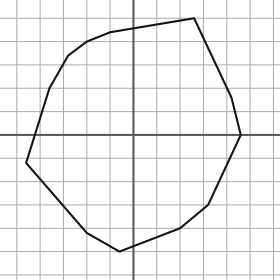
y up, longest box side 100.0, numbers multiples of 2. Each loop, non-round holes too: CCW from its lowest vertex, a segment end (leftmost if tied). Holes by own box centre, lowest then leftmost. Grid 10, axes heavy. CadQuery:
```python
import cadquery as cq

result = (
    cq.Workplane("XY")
    .moveTo(-6.0, -50.0)
    .lineTo(20.0, -40.0)
    .lineTo(32.0, -30.0)
    .lineTo(46.0, 0.0)
    .lineTo(42.0, 16.0)
    .lineTo(26.0, 50.0)
    .lineTo(-10.0, 44.0)
    .lineTo(-20.0, 40.0)
    .lineTo(-28.0, 34.0)
    .lineTo(-36.0, 20.0)
    .lineTo(-46.0, -12.0)
    .lineTo(-20.0, -42.0)
    .close()
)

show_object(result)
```